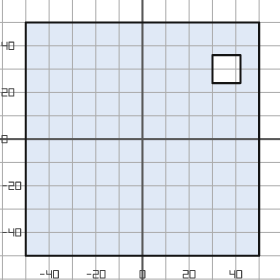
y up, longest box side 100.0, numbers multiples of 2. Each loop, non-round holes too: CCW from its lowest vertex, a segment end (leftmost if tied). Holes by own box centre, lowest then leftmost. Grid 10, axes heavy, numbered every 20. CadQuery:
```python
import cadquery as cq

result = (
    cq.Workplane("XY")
    .moveTo(-50.0, -50.0)
    .lineTo(50.0, -50.0)
    .lineTo(50.0, 50.0)
    .lineTo(-50.0, 50.0)
    .close()
    .moveTo(30.0, 24.0)
    .lineTo(42.0, 24.0)
    .lineTo(42.0, 36.0)
    .lineTo(30.0, 36.0)
    .close()
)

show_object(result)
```